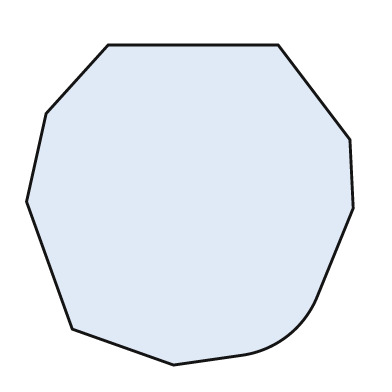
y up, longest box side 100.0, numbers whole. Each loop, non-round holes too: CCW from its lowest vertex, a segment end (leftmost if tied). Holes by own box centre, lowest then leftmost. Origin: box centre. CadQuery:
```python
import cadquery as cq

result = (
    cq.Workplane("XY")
    .moveTo(-5.0, -49.0)
    .lineTo(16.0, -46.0)
    .threePointArc((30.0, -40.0), (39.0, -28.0))
    .lineTo(50.0, -1.0)
    .lineTo(49.0, 20.0)
    .lineTo(27.0, 49.0)
    .lineTo(-25.0, 49.0)
    .lineTo(-44.0, 28.0)
    .lineTo(-50.0, 1.0)
    .lineTo(-36.0, -38.0)
    .close()
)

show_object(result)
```